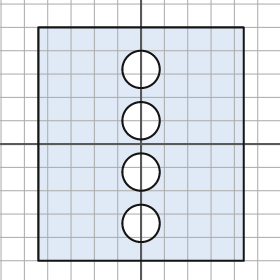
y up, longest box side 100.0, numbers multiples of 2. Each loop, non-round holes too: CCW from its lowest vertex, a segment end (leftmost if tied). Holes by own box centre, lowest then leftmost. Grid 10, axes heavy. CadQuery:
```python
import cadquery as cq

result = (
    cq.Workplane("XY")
    .moveTo(-44.0, -50.0)
    .lineTo(44.0, -50.0)
    .lineTo(44.0, 50.0)
    .lineTo(-44.0, 50.0)
    .close()
    .moveTo(0.0, -34.0)
    .circle(8.0)
    .moveTo(0.0, -12.0)
    .circle(8.0)
    .moveTo(0.0, 10.0)
    .circle(8.0)
    .moveTo(0.0, 32.0)
    .circle(8.0)
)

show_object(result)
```